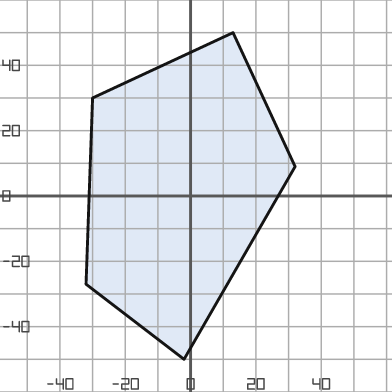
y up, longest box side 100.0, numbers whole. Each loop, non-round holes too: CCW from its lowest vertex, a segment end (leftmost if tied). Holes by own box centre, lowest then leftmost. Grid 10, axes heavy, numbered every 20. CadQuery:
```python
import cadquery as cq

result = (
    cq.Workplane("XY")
    .moveTo(-2.0, -50.0)
    .lineTo(32.0, 9.0)
    .lineTo(13.0, 50.0)
    .lineTo(-30.0, 30.0)
    .lineTo(-32.0, -27.0)
    .close()
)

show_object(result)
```